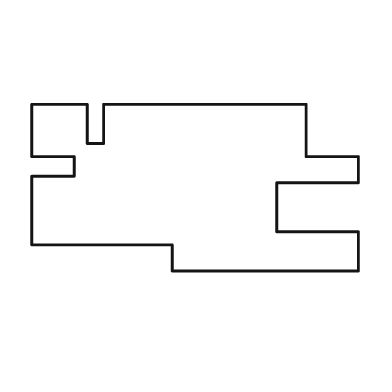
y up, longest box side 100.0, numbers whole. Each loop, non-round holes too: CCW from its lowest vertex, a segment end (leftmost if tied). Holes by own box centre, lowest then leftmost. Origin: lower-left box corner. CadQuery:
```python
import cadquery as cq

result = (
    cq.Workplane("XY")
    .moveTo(43.0, 0.0)
    .lineTo(100.0, 0.0)
    .lineTo(100.0, 12.0)
    .lineTo(75.0, 12.0)
    .lineTo(75.0, 27.0)
    .lineTo(100.0, 27.0)
    .lineTo(100.0, 35.0)
    .lineTo(84.0, 35.0)
    .lineTo(84.0, 51.0)
    .lineTo(22.0, 51.0)
    .lineTo(22.0, 39.0)
    .lineTo(17.0, 39.0)
    .lineTo(17.0, 51.0)
    .lineTo(0.0, 51.0)
    .lineTo(0.0, 35.0)
    .lineTo(13.0, 35.0)
    .lineTo(13.0, 29.0)
    .lineTo(0.0, 29.0)
    .lineTo(0.0, 8.0)
    .lineTo(43.0, 8.0)
    .close()
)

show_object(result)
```